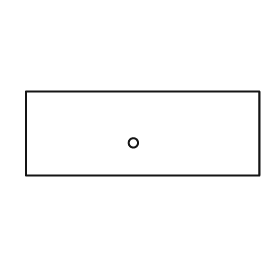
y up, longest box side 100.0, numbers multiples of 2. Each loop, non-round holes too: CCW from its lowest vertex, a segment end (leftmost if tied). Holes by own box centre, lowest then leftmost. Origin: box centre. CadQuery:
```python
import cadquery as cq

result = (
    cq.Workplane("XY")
    .moveTo(-50.0, -18.0)
    .lineTo(50.0, -18.0)
    .lineTo(50.0, 18.0)
    .lineTo(-50.0, 18.0)
    .close()
    .moveTo(-4.0, -4.0)
    .circle(2.0)
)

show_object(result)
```